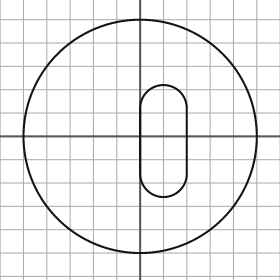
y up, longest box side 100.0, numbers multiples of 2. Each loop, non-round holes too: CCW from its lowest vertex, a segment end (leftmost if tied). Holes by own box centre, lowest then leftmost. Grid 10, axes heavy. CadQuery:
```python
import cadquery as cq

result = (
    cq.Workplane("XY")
    .moveTo(0.0, 0.0)
    .circle(50.0)
    .moveTo(0.0, -16.0)
    .threePointArc((10.0, -26.0), (20.0, -16.0))
    .lineTo(20.0, 12.0)
    .threePointArc((10.0, 22.0), (0.0, 12.0))
    .close()
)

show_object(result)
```